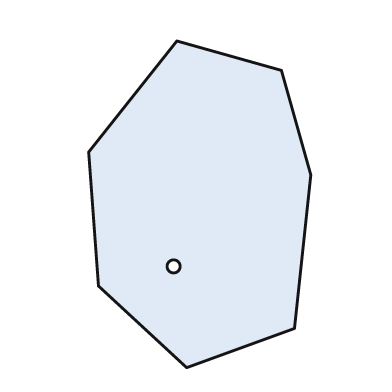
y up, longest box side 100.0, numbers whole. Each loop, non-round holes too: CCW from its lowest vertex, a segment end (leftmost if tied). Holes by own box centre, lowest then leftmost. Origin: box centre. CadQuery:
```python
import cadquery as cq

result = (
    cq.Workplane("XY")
    .moveTo(-4.0, -50.0)
    .lineTo(29.0, -38.0)
    .lineTo(34.0, 9.0)
    .lineTo(25.0, 41.0)
    .lineTo(-7.0, 50.0)
    .lineTo(-34.0, 16.0)
    .lineTo(-31.0, -25.0)
    .close()
    .moveTo(-8.0, -19.0)
    .circle(2.0)
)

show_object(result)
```